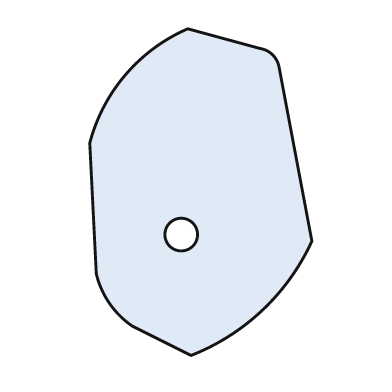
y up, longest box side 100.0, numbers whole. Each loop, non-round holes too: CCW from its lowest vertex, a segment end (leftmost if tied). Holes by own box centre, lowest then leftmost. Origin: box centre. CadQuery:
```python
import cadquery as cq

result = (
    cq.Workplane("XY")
    .moveTo(-3.0, -50.0)
    .threePointArc((19.0, -36.0), (34.0, -15.0))
    .lineTo(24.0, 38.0)
    .threePointArc((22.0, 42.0), (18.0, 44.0))
    .lineTo(-4.0, 50.0)
    .threePointArc((-23.0, 36.0), (-34.0, 15.0))
    .lineTo(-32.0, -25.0)
    .threePointArc((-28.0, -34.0), (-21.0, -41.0))
    .close()
    .moveTo(-6.0, -13.0)
    .circle(5.0)
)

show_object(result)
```